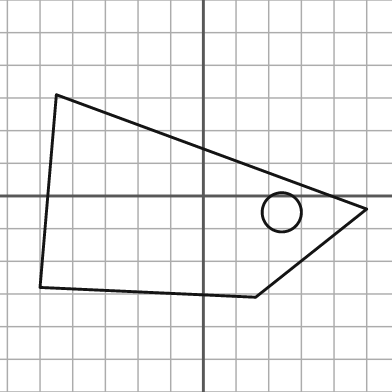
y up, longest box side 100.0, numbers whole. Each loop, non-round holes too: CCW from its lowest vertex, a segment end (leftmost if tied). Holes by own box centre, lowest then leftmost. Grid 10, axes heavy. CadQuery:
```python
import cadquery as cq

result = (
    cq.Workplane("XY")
    .moveTo(16.0, -31.0)
    .lineTo(50.0, -4.0)
    .lineTo(-45.0, 31.0)
    .lineTo(-50.0, -28.0)
    .close()
    .moveTo(24.0, -5.0)
    .circle(6.0)
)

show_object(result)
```